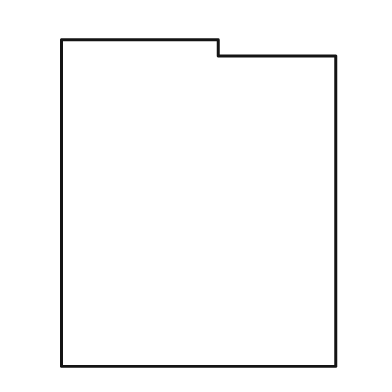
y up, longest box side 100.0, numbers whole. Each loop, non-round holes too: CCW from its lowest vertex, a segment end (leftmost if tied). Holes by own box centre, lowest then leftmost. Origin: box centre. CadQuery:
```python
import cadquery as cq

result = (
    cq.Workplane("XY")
    .moveTo(-42.0, -50.0)
    .lineTo(42.0, -50.0)
    .lineTo(42.0, 45.0)
    .lineTo(6.0, 45.0)
    .lineTo(6.0, 50.0)
    .lineTo(-42.0, 50.0)
    .close()
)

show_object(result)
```